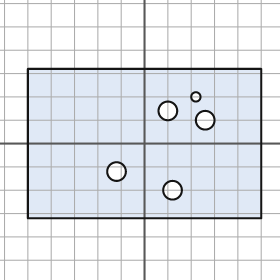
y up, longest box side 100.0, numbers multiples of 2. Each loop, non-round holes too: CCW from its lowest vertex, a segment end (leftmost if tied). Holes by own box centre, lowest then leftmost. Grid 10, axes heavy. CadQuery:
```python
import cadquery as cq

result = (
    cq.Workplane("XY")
    .moveTo(-50.0, -32.0)
    .lineTo(50.0, -32.0)
    .lineTo(50.0, 32.0)
    .lineTo(-50.0, 32.0)
    .close()
    .moveTo(12.0, -20.0)
    .circle(4.0)
    .moveTo(-12.0, -12.0)
    .circle(4.0)
    .moveTo(26.0, 10.0)
    .circle(4.0)
    .moveTo(10.0, 14.0)
    .circle(4.0)
    .moveTo(22.0, 20.0)
    .circle(2.0)
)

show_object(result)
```